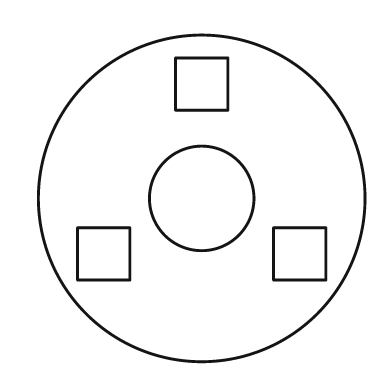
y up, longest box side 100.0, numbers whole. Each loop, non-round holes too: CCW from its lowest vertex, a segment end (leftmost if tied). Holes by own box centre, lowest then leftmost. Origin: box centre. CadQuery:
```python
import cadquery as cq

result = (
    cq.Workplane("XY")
    .moveTo(0.0, 0.0)
    .circle(50.0)
    .moveTo(-38.0, -25.0)
    .lineTo(-22.0, -25.0)
    .lineTo(-22.0, -9.0)
    .lineTo(-38.0, -9.0)
    .close()
    .moveTo(22.0, -25.0)
    .lineTo(38.0, -25.0)
    .lineTo(38.0, -9.0)
    .lineTo(22.0, -9.0)
    .close()
    .moveTo(0.0, 0.0)
    .circle(16.0)
    .moveTo(-8.0, 27.0)
    .lineTo(8.0, 27.0)
    .lineTo(8.0, 43.0)
    .lineTo(-8.0, 43.0)
    .close()
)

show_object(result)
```